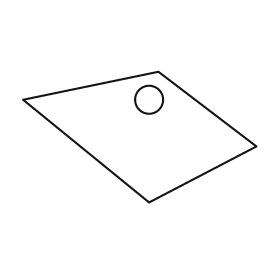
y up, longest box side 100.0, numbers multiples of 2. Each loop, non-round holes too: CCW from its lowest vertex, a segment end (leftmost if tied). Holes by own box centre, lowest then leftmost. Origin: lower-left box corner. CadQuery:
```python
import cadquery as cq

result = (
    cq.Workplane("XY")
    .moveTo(54.0, 0.0)
    .lineTo(100.0, 24.0)
    .lineTo(58.0, 56.0)
    .lineTo(0.0, 44.0)
    .close()
    .moveTo(54.0, 44.0)
    .circle(6.0)
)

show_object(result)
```